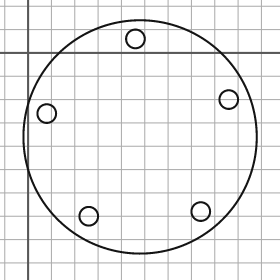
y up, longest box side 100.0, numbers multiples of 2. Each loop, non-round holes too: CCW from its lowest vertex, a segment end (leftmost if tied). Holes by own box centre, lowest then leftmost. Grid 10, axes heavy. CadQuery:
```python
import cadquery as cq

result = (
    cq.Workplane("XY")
    .moveTo(48.0, -36.0)
    .circle(50.0)
    .moveTo(26.0, -70.0)
    .circle(4.0)
    .moveTo(74.0, -68.0)
    .circle(4.0)
    .moveTo(8.0, -26.0)
    .circle(4.0)
    .moveTo(86.0, -20.0)
    .circle(4.0)
    .moveTo(46.0, 6.0)
    .circle(4.0)
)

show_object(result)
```